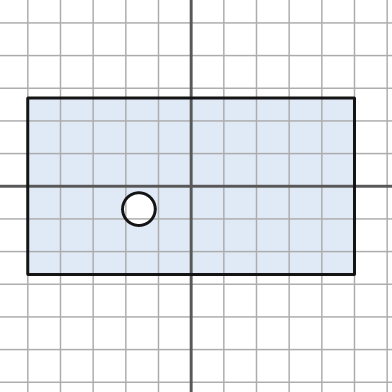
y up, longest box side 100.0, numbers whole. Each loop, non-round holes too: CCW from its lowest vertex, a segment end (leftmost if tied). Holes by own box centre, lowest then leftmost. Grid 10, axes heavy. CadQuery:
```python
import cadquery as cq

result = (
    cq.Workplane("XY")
    .moveTo(-50.0, -27.0)
    .lineTo(50.0, -27.0)
    .lineTo(50.0, 27.0)
    .lineTo(-50.0, 27.0)
    .close()
    .moveTo(-16.0, -7.0)
    .circle(5.0)
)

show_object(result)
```